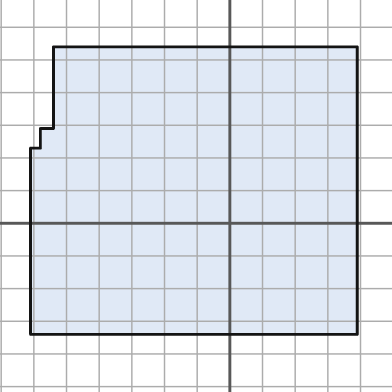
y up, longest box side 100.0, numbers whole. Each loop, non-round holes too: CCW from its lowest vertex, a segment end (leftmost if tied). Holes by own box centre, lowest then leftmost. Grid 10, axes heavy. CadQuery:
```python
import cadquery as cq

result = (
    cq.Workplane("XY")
    .moveTo(-61.0, -34.0)
    .lineTo(39.0, -34.0)
    .lineTo(39.0, 54.0)
    .lineTo(-54.0, 54.0)
    .lineTo(-54.0, 29.0)
    .lineTo(-58.0, 29.0)
    .lineTo(-58.0, 23.0)
    .lineTo(-61.0, 23.0)
    .close()
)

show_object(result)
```